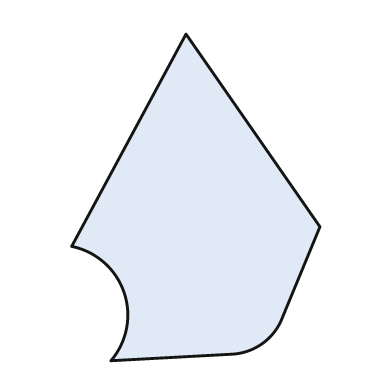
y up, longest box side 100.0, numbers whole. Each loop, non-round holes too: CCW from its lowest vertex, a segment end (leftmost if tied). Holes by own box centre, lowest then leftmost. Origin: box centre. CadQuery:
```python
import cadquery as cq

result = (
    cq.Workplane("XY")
    .moveTo(-26.0, -50.0)
    .lineTo(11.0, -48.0)
    .threePointArc((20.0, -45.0), (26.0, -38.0))
    .lineTo(38.0, -9.0)
    .lineTo(-3.0, 50.0)
    .lineTo(-38.0, -15.0)
    .threePointArc((-22.0, -29.0), (-26.0, -50.0))
    .close()
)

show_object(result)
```